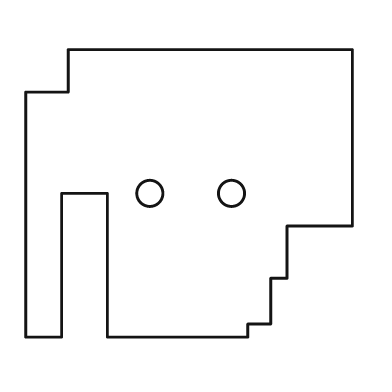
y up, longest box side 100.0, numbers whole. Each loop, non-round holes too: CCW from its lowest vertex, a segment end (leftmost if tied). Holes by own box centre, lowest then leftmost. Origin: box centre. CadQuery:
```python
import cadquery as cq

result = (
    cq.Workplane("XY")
    .moveTo(-50.0, -44.0)
    .lineTo(-39.0, -44.0)
    .lineTo(-39.0, 0.0)
    .lineTo(-25.0, 0.0)
    .lineTo(-25.0, -44.0)
    .lineTo(18.0, -44.0)
    .lineTo(18.0, -40.0)
    .lineTo(25.0, -40.0)
    .lineTo(25.0, -26.0)
    .lineTo(30.0, -26.0)
    .lineTo(30.0, -10.0)
    .lineTo(50.0, -10.0)
    .lineTo(50.0, 44.0)
    .lineTo(-37.0, 44.0)
    .lineTo(-37.0, 31.0)
    .lineTo(-50.0, 31.0)
    .close()
    .moveTo(-12.0, 0.0)
    .circle(4.0)
    .moveTo(13.0, 0.0)
    .circle(4.0)
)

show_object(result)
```